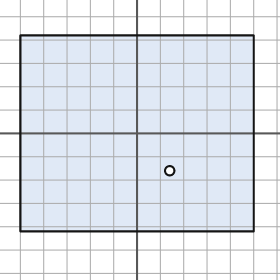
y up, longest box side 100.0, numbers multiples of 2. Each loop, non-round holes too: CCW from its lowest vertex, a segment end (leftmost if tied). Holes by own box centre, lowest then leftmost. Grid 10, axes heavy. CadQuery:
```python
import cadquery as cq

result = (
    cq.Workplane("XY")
    .moveTo(-50.0, -42.0)
    .lineTo(50.0, -42.0)
    .lineTo(50.0, 42.0)
    .lineTo(-50.0, 42.0)
    .close()
    .moveTo(14.0, -16.0)
    .circle(2.0)
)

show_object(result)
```